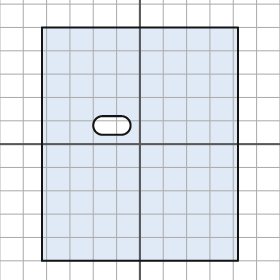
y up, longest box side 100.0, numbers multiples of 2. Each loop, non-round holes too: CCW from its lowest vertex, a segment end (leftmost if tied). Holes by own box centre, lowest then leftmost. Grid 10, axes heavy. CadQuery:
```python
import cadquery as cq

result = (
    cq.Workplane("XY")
    .moveTo(-42.0, -50.0)
    .lineTo(42.0, -50.0)
    .lineTo(42.0, 50.0)
    .lineTo(-42.0, 50.0)
    .close()
    .moveTo(-16.0, 4.0)
    .lineTo(-8.0, 4.0)
    .threePointArc((-4.0, 8.0), (-8.0, 12.0))
    .lineTo(-16.0, 12.0)
    .threePointArc((-20.0, 8.0), (-16.0, 4.0))
    .close()
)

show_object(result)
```